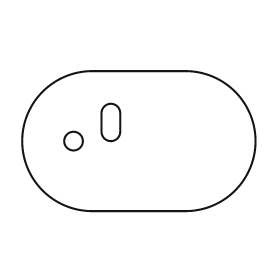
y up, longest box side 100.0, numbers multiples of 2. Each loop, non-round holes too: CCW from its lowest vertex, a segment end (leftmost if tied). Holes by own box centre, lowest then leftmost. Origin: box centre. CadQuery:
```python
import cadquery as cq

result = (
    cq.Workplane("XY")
    .moveTo(-20.0, -30.0)
    .lineTo(20.0, -30.0)
    .threePointArc((50.0, 0.0), (20.0, 30.0))
    .lineTo(-20.0, 30.0)
    .threePointArc((-50.0, 0.0), (-20.0, -30.0))
    .close()
    .moveTo(-28.0, 0.0)
    .circle(4.0)
    .moveTo(-16.0, 4.0)
    .threePointArc((-12.0, 0.0), (-8.0, 4.0))
    .lineTo(-8.0, 12.0)
    .threePointArc((-12.0, 16.0), (-16.0, 12.0))
    .close()
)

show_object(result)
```